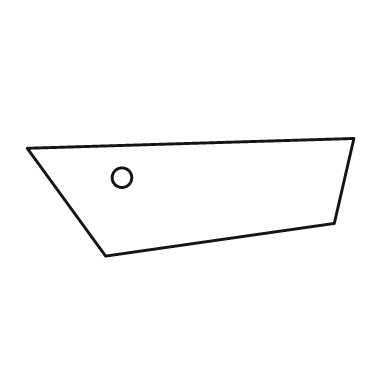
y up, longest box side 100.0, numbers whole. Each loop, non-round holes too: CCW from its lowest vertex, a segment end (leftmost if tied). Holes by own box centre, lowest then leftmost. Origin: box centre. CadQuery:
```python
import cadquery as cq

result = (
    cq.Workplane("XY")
    .moveTo(-26.0, -18.0)
    .lineTo(44.0, -8.0)
    .lineTo(50.0, 18.0)
    .lineTo(-50.0, 15.0)
    .close()
    .moveTo(-21.0, 6.0)
    .circle(3.0)
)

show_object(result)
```